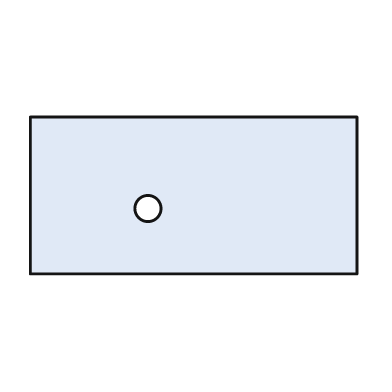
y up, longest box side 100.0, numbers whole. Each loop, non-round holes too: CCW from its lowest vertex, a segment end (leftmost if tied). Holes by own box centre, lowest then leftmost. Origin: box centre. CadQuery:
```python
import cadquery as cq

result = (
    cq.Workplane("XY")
    .moveTo(-50.0, -24.0)
    .lineTo(50.0, -24.0)
    .lineTo(50.0, 24.0)
    .lineTo(-50.0, 24.0)
    .close()
    .moveTo(-14.0, -4.0)
    .circle(4.0)
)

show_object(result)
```